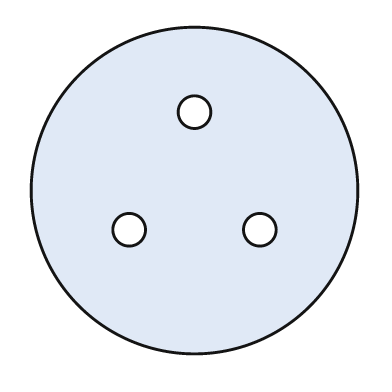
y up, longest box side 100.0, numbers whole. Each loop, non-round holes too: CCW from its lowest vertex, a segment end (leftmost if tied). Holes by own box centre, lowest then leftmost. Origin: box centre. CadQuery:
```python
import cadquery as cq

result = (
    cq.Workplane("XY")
    .moveTo(0.0, 0.0)
    .circle(50.0)
    .moveTo(-20.0, -12.0)
    .circle(5.0)
    .moveTo(20.0, -12.0)
    .circle(5.0)
    .moveTo(0.0, 24.0)
    .circle(5.0)
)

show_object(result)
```